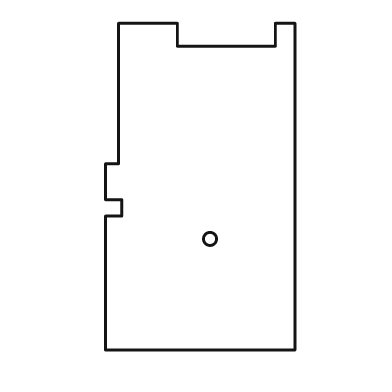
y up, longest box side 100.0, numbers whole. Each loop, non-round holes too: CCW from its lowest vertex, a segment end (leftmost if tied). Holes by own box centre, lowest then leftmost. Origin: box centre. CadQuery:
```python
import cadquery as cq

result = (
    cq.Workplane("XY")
    .moveTo(-29.0, -50.0)
    .lineTo(29.0, -50.0)
    .lineTo(29.0, 50.0)
    .lineTo(23.0, 50.0)
    .lineTo(23.0, 43.0)
    .lineTo(-7.0, 43.0)
    .lineTo(-7.0, 50.0)
    .lineTo(-25.0, 50.0)
    .lineTo(-25.0, 7.0)
    .lineTo(-29.0, 7.0)
    .lineTo(-29.0, -4.0)
    .lineTo(-24.0, -4.0)
    .lineTo(-24.0, -9.0)
    .lineTo(-29.0, -9.0)
    .close()
    .moveTo(3.0, -16.0)
    .circle(2.0)
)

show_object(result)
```